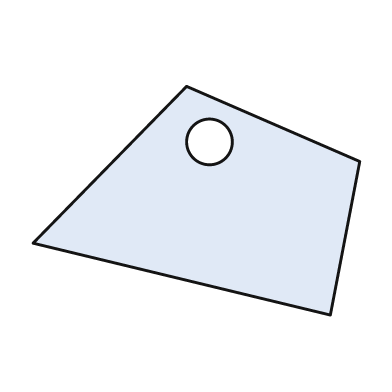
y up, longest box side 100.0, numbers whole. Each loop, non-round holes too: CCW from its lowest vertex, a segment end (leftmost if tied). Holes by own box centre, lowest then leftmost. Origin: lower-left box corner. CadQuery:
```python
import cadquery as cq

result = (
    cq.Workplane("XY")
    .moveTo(91.0, 0.0)
    .lineTo(100.0, 47.0)
    .lineTo(47.0, 70.0)
    .lineTo(0.0, 22.0)
    .close()
    .moveTo(54.0, 53.0)
    .circle(7.0)
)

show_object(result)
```